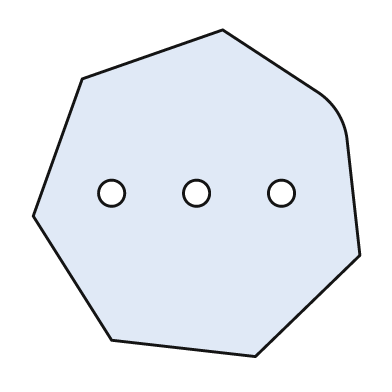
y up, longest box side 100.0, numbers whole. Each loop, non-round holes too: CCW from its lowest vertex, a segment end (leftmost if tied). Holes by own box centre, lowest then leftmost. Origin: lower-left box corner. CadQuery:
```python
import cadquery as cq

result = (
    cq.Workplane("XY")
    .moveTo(68.0, 0.0)
    .lineTo(100.0, 31.0)
    .lineTo(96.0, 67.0)
    .threePointArc((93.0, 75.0), (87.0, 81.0))
    .lineTo(58.0, 100.0)
    .lineTo(15.0, 85.0)
    .lineTo(0.0, 43.0)
    .lineTo(24.0, 5.0)
    .close()
    .moveTo(24.0, 50.0)
    .circle(4.0)
    .moveTo(50.0, 50.0)
    .circle(4.0)
    .moveTo(76.0, 50.0)
    .circle(4.0)
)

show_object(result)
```